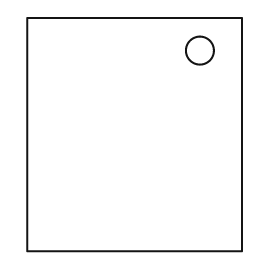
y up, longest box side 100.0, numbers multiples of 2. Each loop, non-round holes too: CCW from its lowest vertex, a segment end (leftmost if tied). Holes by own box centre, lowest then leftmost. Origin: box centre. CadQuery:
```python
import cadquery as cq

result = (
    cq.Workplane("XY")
    .moveTo(-46.0, -50.0)
    .lineTo(46.0, -50.0)
    .lineTo(46.0, 50.0)
    .lineTo(-46.0, 50.0)
    .close()
    .moveTo(28.0, 36.0)
    .circle(6.0)
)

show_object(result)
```